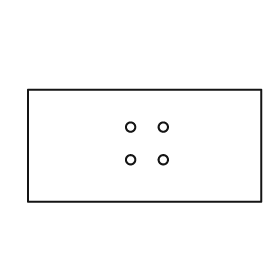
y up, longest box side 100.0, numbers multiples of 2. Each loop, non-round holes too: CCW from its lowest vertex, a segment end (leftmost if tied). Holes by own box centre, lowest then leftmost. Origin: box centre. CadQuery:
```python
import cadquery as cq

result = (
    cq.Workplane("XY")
    .moveTo(-50.0, -24.0)
    .lineTo(50.0, -24.0)
    .lineTo(50.0, 24.0)
    .lineTo(-50.0, 24.0)
    .close()
    .moveTo(-6.0, -6.0)
    .circle(2.0)
    .moveTo(8.0, -6.0)
    .circle(2.0)
    .moveTo(-6.0, 8.0)
    .circle(2.0)
    .moveTo(8.0, 8.0)
    .circle(2.0)
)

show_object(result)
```